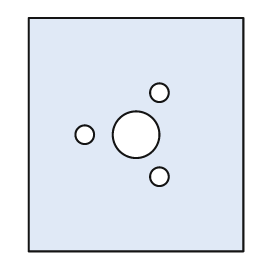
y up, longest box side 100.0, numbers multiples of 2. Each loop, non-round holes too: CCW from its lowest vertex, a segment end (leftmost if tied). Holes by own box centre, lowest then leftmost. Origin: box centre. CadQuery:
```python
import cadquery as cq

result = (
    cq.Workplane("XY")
    .moveTo(-46.0, -50.0)
    .lineTo(46.0, -50.0)
    .lineTo(46.0, 50.0)
    .lineTo(-46.0, 50.0)
    .close()
    .moveTo(10.0, -18.0)
    .circle(4.0)
    .moveTo(-22.0, 0.0)
    .circle(4.0)
    .moveTo(0.0, 0.0)
    .circle(10.0)
    .moveTo(10.0, 18.0)
    .circle(4.0)
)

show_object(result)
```